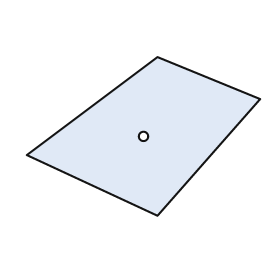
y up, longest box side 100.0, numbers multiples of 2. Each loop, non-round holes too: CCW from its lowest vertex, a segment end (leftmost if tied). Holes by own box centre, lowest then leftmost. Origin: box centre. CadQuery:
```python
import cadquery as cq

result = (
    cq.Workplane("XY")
    .moveTo(6.0, -34.0)
    .lineTo(50.0, 16.0)
    .lineTo(6.0, 34.0)
    .lineTo(-50.0, -8.0)
    .close()
    .moveTo(0.0, 0.0)
    .circle(2.0)
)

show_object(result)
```